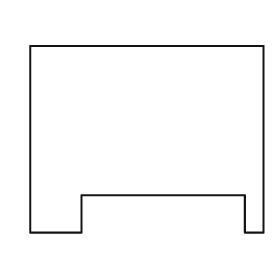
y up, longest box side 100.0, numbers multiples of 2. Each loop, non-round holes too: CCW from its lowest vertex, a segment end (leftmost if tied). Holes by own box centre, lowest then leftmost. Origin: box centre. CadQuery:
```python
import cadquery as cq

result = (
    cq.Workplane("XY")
    .moveTo(-50.0, -40.0)
    .lineTo(-28.0, -40.0)
    .lineTo(-28.0, -24.0)
    .lineTo(42.0, -24.0)
    .lineTo(42.0, -40.0)
    .lineTo(50.0, -40.0)
    .lineTo(50.0, 40.0)
    .lineTo(-50.0, 40.0)
    .close()
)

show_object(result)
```